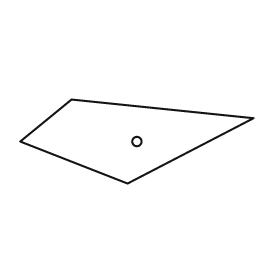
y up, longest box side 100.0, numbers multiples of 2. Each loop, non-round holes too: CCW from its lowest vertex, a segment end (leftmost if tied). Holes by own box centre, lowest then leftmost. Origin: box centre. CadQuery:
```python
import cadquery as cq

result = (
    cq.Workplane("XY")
    .moveTo(-4.0, -18.0)
    .lineTo(50.0, 10.0)
    .lineTo(-28.0, 18.0)
    .lineTo(-50.0, 0.0)
    .close()
    .moveTo(0.0, 0.0)
    .circle(2.0)
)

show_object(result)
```